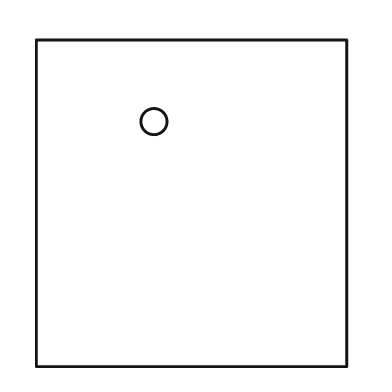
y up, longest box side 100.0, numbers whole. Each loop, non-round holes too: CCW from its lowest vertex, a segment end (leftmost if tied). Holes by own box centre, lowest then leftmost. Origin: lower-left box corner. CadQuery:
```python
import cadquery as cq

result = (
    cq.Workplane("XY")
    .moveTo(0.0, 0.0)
    .lineTo(95.0, 0.0)
    .lineTo(95.0, 100.0)
    .lineTo(0.0, 100.0)
    .close()
    .moveTo(36.0, 75.0)
    .circle(4.0)
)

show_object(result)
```